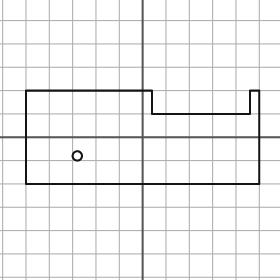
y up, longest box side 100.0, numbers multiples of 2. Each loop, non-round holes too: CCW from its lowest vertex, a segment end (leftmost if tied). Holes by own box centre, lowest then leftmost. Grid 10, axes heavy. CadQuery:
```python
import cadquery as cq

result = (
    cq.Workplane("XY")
    .moveTo(-50.0, -20.0)
    .lineTo(50.0, -20.0)
    .lineTo(50.0, 20.0)
    .lineTo(46.0, 20.0)
    .lineTo(46.0, 10.0)
    .lineTo(4.0, 10.0)
    .lineTo(4.0, 20.0)
    .lineTo(-50.0, 20.0)
    .close()
    .moveTo(-28.0, -8.0)
    .circle(2.0)
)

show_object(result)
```